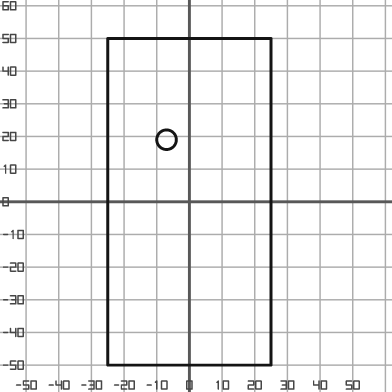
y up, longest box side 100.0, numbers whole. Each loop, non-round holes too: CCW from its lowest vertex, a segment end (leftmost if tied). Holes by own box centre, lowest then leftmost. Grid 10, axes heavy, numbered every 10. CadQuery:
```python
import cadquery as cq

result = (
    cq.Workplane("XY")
    .moveTo(-25.0, -50.0)
    .lineTo(25.0, -50.0)
    .lineTo(25.0, 50.0)
    .lineTo(-25.0, 50.0)
    .close()
    .moveTo(-7.0, 19.0)
    .circle(3.0)
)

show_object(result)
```